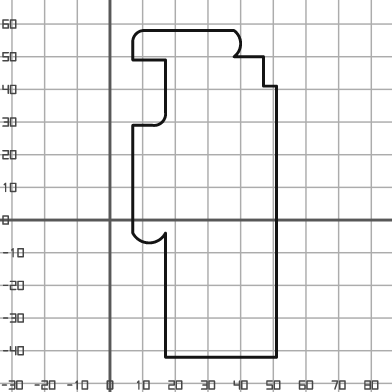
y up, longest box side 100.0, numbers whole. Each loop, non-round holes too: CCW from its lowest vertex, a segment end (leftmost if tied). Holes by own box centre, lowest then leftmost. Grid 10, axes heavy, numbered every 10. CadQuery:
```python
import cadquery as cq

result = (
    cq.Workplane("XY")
    .moveTo(17.0, -42.0)
    .lineTo(51.0, -42.0)
    .lineTo(51.0, 41.0)
    .lineTo(47.0, 41.0)
    .lineTo(47.0, 50.0)
    .lineTo(38.0, 50.0)
    .threePointArc((40.0, 54.0), (38.0, 58.0))
    .lineTo(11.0, 58.0)
    .threePointArc((8.0, 57.0), (7.0, 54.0))
    .lineTo(7.0, 49.0)
    .lineTo(17.0, 49.0)
    .lineTo(17.0, 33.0)
    .threePointArc((16.0, 30.0), (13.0, 29.0))
    .lineTo(7.0, 29.0)
    .lineTo(7.0, -4.0)
    .threePointArc((12.0, -7.0), (17.0, -4.0))
    .close()
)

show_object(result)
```